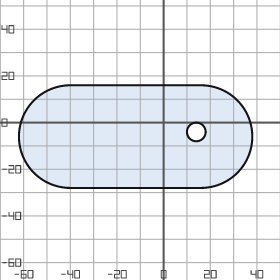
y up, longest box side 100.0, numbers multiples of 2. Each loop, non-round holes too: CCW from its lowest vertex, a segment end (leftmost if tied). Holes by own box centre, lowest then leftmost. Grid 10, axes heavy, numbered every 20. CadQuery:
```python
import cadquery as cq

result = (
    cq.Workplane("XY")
    .moveTo(-40.0, -28.0)
    .lineTo(16.0, -28.0)
    .threePointArc((38.0, -6.0), (16.0, 16.0))
    .lineTo(-40.0, 16.0)
    .threePointArc((-62.0, -6.0), (-40.0, -28.0))
    .close()
    .moveTo(14.0, -4.0)
    .circle(4.0)
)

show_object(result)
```